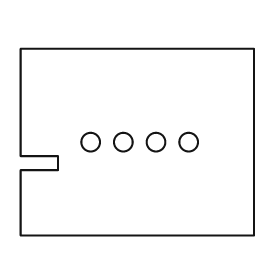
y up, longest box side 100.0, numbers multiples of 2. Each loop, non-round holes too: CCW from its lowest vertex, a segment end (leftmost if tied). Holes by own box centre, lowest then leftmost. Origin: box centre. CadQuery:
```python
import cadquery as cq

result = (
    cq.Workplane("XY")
    .moveTo(-50.0, -40.0)
    .lineTo(50.0, -40.0)
    .lineTo(50.0, 40.0)
    .lineTo(-50.0, 40.0)
    .lineTo(-50.0, -6.0)
    .lineTo(-34.0, -6.0)
    .lineTo(-34.0, -12.0)
    .lineTo(-50.0, -12.0)
    .close()
    .moveTo(-20.0, 0.0)
    .circle(4.0)
    .moveTo(-6.0, 0.0)
    .circle(4.0)
    .moveTo(8.0, 0.0)
    .circle(4.0)
    .moveTo(22.0, 0.0)
    .circle(4.0)
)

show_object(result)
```